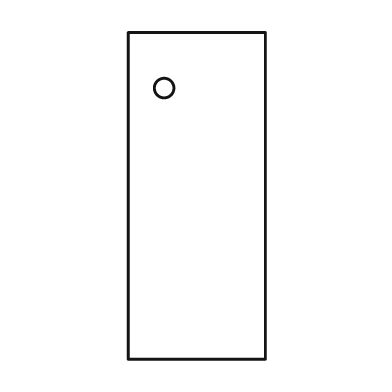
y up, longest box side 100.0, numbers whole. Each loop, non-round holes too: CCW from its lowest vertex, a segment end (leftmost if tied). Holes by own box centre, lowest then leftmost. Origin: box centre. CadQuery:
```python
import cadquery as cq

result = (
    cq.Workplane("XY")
    .moveTo(-21.0, -50.0)
    .lineTo(21.0, -50.0)
    .lineTo(21.0, 50.0)
    .lineTo(-21.0, 50.0)
    .close()
    .moveTo(-10.0, 33.0)
    .circle(3.0)
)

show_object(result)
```